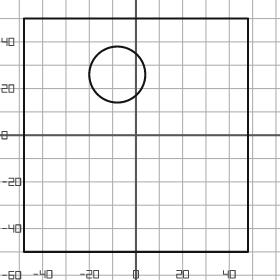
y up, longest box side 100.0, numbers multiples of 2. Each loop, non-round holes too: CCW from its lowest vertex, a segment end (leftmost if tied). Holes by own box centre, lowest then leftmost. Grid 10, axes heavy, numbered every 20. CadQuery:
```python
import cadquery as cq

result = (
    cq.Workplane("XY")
    .moveTo(-48.0, -50.0)
    .lineTo(48.0, -50.0)
    .lineTo(48.0, 50.0)
    .lineTo(-48.0, 50.0)
    .close()
    .moveTo(-8.0, 26.0)
    .circle(12.0)
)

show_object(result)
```